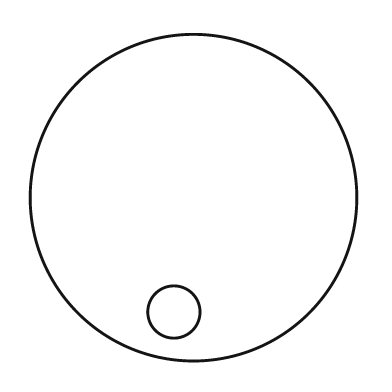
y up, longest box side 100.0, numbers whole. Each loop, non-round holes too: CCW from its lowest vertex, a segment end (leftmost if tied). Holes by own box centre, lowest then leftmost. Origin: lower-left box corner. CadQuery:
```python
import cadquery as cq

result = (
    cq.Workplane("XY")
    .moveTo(50.0, 50.0)
    .circle(50.0)
    .moveTo(44.0, 15.0)
    .circle(8.0)
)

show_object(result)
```